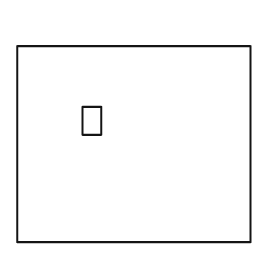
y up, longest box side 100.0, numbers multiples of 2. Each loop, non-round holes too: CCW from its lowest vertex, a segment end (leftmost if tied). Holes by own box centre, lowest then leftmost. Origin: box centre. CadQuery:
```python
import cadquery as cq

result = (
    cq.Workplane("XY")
    .moveTo(-50.0, -42.0)
    .lineTo(50.0, -42.0)
    .lineTo(50.0, 42.0)
    .lineTo(-50.0, 42.0)
    .close()
    .moveTo(-22.0, 4.0)
    .lineTo(-14.0, 4.0)
    .lineTo(-14.0, 16.0)
    .lineTo(-22.0, 16.0)
    .close()
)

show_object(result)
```